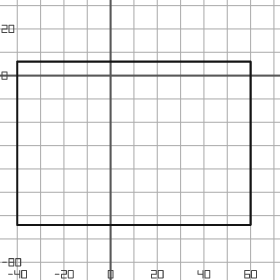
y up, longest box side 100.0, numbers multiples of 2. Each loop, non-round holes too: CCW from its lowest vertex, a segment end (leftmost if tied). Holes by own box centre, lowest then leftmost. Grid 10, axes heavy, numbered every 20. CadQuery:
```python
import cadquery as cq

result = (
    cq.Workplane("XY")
    .moveTo(-40.0, -64.0)
    .lineTo(60.0, -64.0)
    .lineTo(60.0, 6.0)
    .lineTo(-40.0, 6.0)
    .close()
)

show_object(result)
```